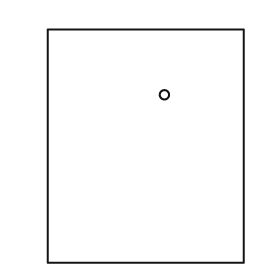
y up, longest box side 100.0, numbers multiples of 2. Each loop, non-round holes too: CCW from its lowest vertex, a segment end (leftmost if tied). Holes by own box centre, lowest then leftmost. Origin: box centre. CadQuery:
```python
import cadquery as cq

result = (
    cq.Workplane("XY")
    .moveTo(-42.0, -50.0)
    .lineTo(42.0, -50.0)
    .lineTo(42.0, 50.0)
    .lineTo(-42.0, 50.0)
    .close()
    .moveTo(8.0, 22.0)
    .circle(2.0)
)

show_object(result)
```